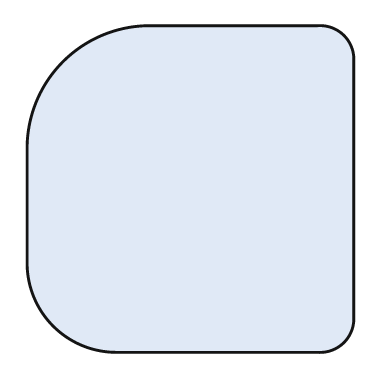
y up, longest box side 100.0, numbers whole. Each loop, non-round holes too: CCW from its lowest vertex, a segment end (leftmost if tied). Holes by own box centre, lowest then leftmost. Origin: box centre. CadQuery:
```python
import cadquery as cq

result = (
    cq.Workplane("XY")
    .moveTo(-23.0, -50.0)
    .lineTo(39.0, -50.0)
    .threePointArc((47.0, -47.0), (50.0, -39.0))
    .lineTo(50.0, 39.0)
    .threePointArc((47.0, 47.0), (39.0, 50.0))
    .lineTo(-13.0, 50.0)
    .threePointArc((-39.0, 39.0), (-50.0, 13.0))
    .lineTo(-50.0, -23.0)
    .threePointArc((-42.0, -42.0), (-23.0, -50.0))
    .close()
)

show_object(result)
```